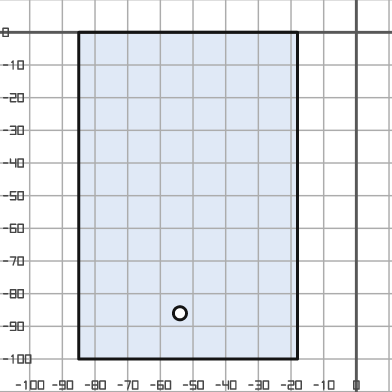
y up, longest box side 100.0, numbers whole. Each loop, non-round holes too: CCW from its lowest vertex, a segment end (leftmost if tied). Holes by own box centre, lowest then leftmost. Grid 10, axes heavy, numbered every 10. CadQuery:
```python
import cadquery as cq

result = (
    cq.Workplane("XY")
    .moveTo(-85.0, -100.0)
    .lineTo(-18.0, -100.0)
    .lineTo(-18.0, 0.0)
    .lineTo(-85.0, 0.0)
    .close()
    .moveTo(-54.0, -86.0)
    .circle(2.0)
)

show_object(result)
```